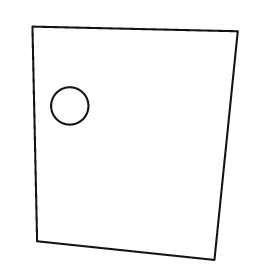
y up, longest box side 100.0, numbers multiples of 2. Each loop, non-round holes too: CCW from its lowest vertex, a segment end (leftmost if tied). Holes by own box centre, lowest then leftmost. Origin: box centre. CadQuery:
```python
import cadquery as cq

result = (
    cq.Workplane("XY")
    .moveTo(34.0, -50.0)
    .lineTo(44.0, 48.0)
    .lineTo(-44.0, 50.0)
    .lineTo(-42.0, -42.0)
    .close()
    .moveTo(-28.0, 16.0)
    .circle(8.0)
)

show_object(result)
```